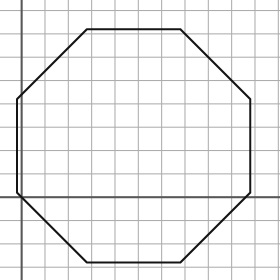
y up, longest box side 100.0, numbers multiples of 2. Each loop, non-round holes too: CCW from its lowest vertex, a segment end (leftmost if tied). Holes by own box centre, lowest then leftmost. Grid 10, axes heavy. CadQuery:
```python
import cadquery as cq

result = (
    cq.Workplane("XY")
    .moveTo(28.0, -28.0)
    .lineTo(68.0, -28.0)
    .lineTo(98.0, 2.0)
    .lineTo(98.0, 42.0)
    .lineTo(68.0, 72.0)
    .lineTo(28.0, 72.0)
    .lineTo(-2.0, 42.0)
    .lineTo(-2.0, 2.0)
    .close()
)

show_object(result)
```